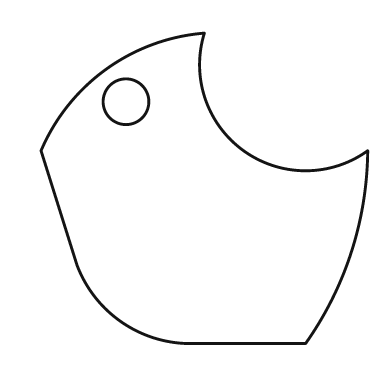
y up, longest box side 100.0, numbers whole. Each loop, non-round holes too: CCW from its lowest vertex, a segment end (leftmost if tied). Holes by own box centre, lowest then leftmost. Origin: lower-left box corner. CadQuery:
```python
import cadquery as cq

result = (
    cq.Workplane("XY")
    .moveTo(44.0, 0.0)
    .lineTo(81.0, 0.0)
    .threePointArc((95.0, 28.0), (100.0, 59.0))
    .threePointArc((62.0, 59.0), (50.0, 95.0))
    .threePointArc((20.0, 84.0), (0.0, 59.0))
    .lineTo(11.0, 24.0)
    .threePointArc((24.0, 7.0), (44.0, 0.0))
    .close()
    .moveTo(26.0, 74.0)
    .circle(7.0)
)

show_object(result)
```